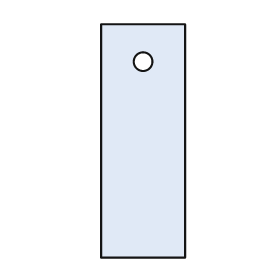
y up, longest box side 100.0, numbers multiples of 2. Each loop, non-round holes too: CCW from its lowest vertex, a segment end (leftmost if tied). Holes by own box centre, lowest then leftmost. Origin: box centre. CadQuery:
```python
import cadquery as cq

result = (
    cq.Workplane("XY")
    .moveTo(-18.0, -50.0)
    .lineTo(18.0, -50.0)
    .lineTo(18.0, 50.0)
    .lineTo(-18.0, 50.0)
    .close()
    .moveTo(0.0, 34.0)
    .circle(4.0)
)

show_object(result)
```